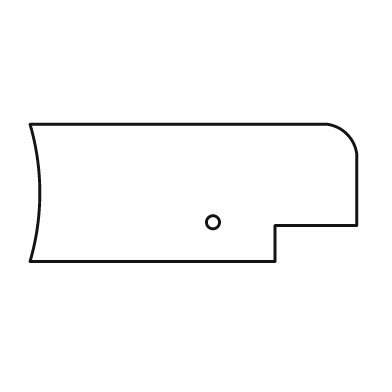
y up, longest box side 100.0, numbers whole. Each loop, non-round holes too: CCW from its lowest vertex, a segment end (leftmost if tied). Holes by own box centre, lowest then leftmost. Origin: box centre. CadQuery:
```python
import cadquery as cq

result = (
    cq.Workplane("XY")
    .moveTo(-50.0, -21.0)
    .lineTo(25.0, -21.0)
    .lineTo(25.0, -10.0)
    .lineTo(50.0, -10.0)
    .lineTo(50.0, 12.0)
    .threePointArc((47.0, 18.0), (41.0, 21.0))
    .lineTo(-50.0, 21.0)
    .threePointArc((-47.0, 0.0), (-50.0, -21.0))
    .close()
    .moveTo(6.0, -9.0)
    .circle(2.0)
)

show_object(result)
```